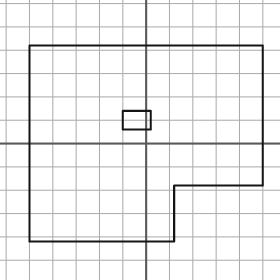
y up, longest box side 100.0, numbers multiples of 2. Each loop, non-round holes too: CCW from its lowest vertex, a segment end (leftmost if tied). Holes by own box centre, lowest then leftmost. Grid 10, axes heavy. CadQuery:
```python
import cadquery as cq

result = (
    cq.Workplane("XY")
    .moveTo(-50.0, -42.0)
    .lineTo(12.0, -42.0)
    .lineTo(12.0, -18.0)
    .lineTo(50.0, -18.0)
    .lineTo(50.0, 42.0)
    .lineTo(-50.0, 42.0)
    .close()
    .moveTo(-10.0, 6.0)
    .lineTo(2.0, 6.0)
    .lineTo(2.0, 14.0)
    .lineTo(-10.0, 14.0)
    .close()
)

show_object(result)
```